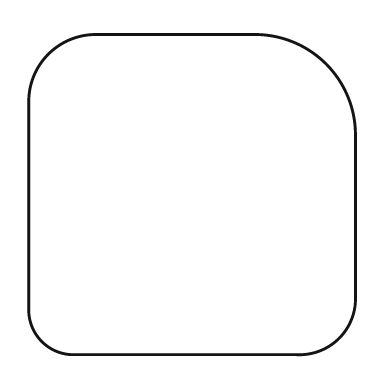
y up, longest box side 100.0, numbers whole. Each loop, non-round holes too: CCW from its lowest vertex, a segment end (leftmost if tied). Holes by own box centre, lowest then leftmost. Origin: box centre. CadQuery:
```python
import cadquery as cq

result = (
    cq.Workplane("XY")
    .moveTo(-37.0, -49.0)
    .lineTo(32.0, -49.0)
    .threePointArc((45.0, -44.0), (50.0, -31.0))
    .lineTo(50.0, 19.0)
    .threePointArc((41.0, 40.0), (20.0, 49.0))
    .lineTo(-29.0, 49.0)
    .threePointArc((-44.0, 43.0), (-50.0, 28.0))
    .lineTo(-50.0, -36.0)
    .threePointArc((-46.0, -45.0), (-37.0, -49.0))
    .close()
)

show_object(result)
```